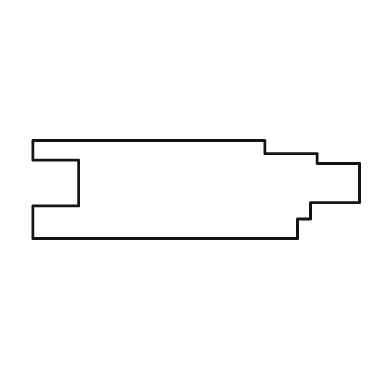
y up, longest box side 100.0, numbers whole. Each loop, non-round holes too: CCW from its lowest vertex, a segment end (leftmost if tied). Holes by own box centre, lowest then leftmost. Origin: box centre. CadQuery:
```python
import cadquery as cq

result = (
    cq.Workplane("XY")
    .moveTo(-50.0, -15.0)
    .lineTo(31.0, -15.0)
    .lineTo(31.0, -9.0)
    .lineTo(35.0, -9.0)
    .lineTo(35.0, -4.0)
    .lineTo(50.0, -4.0)
    .lineTo(50.0, 8.0)
    .lineTo(37.0, 8.0)
    .lineTo(37.0, 11.0)
    .lineTo(21.0, 11.0)
    .lineTo(21.0, 15.0)
    .lineTo(-50.0, 15.0)
    .lineTo(-50.0, 9.0)
    .lineTo(-36.0, 9.0)
    .lineTo(-36.0, -5.0)
    .lineTo(-50.0, -5.0)
    .close()
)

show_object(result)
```